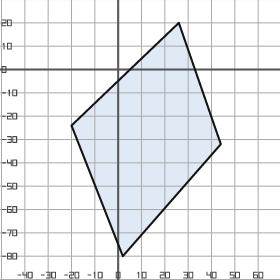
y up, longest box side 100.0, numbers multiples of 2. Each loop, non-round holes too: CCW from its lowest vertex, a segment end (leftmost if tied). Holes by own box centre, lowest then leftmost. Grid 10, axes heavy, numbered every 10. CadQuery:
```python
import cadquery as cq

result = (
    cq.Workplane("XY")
    .moveTo(2.0, -80.0)
    .lineTo(44.0, -32.0)
    .lineTo(26.0, 20.0)
    .lineTo(-20.0, -24.0)
    .close()
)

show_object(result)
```